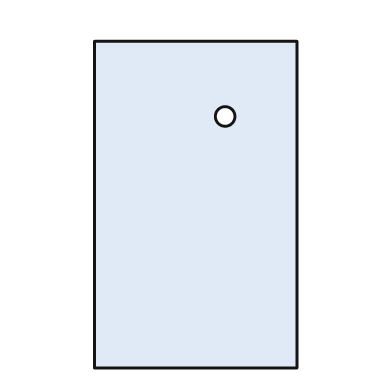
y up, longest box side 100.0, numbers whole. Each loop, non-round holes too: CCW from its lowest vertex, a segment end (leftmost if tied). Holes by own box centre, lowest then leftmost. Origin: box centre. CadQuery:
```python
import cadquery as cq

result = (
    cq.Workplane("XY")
    .moveTo(-31.0, -50.0)
    .lineTo(31.0, -50.0)
    .lineTo(31.0, 50.0)
    .lineTo(-31.0, 50.0)
    .close()
    .moveTo(9.0, 27.0)
    .circle(3.0)
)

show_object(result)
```